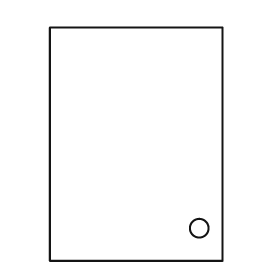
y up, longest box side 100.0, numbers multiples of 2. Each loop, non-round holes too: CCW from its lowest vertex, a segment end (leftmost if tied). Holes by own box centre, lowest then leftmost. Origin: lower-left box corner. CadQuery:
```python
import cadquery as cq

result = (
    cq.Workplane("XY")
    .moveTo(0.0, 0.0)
    .lineTo(74.0, 0.0)
    .lineTo(74.0, 100.0)
    .lineTo(0.0, 100.0)
    .close()
    .moveTo(64.0, 14.0)
    .circle(4.0)
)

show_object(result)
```